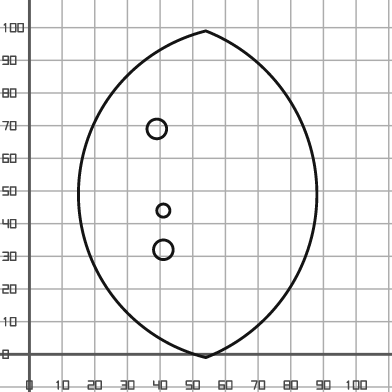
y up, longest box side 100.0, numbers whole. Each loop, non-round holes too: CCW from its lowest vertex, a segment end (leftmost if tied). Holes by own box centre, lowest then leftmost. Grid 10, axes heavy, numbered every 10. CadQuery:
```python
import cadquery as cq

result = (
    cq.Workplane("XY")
    .moveTo(54.0, -1.0)
    .threePointArc((88.0, 49.0), (54.0, 99.0))
    .threePointArc((15.0, 49.0), (54.0, -1.0))
    .close()
    .moveTo(41.0, 32.0)
    .circle(3.0)
    .moveTo(41.0, 44.0)
    .circle(2.0)
    .moveTo(39.0, 69.0)
    .circle(3.0)
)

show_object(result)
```